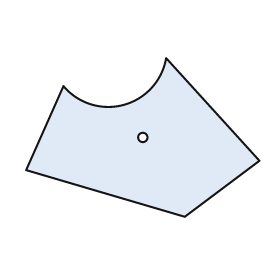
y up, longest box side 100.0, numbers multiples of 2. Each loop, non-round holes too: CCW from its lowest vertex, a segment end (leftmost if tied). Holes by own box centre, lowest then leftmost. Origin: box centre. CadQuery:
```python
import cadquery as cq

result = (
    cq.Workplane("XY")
    .moveTo(18.0, -34.0)
    .lineTo(50.0, -10.0)
    .lineTo(10.0, 34.0)
    .threePointArc((-8.0, 14.0), (-34.0, 22.0))
    .lineTo(-50.0, -14.0)
    .close()
    .moveTo(0.0, 0.0)
    .circle(2.0)
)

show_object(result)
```